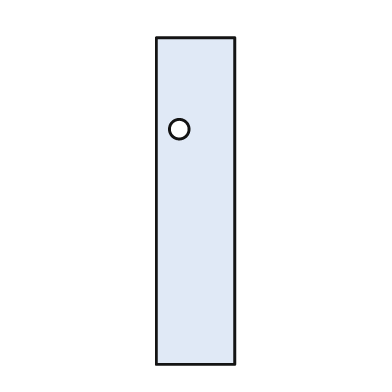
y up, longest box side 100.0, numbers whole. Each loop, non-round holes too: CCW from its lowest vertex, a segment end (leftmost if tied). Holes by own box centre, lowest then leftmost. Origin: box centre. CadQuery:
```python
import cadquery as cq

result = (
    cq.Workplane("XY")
    .moveTo(-12.0, -50.0)
    .lineTo(12.0, -50.0)
    .lineTo(12.0, 50.0)
    .lineTo(-12.0, 50.0)
    .close()
    .moveTo(-5.0, 22.0)
    .circle(3.0)
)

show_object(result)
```